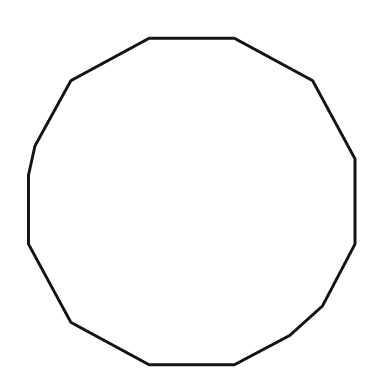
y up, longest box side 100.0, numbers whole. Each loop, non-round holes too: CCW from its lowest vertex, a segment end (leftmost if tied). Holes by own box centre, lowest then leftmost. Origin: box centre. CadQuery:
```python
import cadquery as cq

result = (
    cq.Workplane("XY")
    .moveTo(-13.0, -50.0)
    .lineTo(13.0, -50.0)
    .lineTo(30.0, -41.0)
    .lineTo(40.0, -32.0)
    .lineTo(50.0, -13.0)
    .lineTo(50.0, 13.0)
    .lineTo(37.0, 37.0)
    .lineTo(13.0, 50.0)
    .lineTo(-13.0, 50.0)
    .lineTo(-37.0, 37.0)
    .lineTo(-48.0, 17.0)
    .lineTo(-50.0, 8.0)
    .lineTo(-50.0, -13.0)
    .lineTo(-37.0, -37.0)
    .close()
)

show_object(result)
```